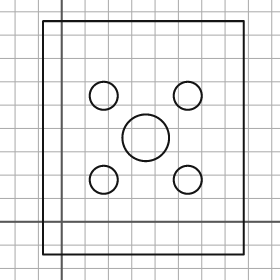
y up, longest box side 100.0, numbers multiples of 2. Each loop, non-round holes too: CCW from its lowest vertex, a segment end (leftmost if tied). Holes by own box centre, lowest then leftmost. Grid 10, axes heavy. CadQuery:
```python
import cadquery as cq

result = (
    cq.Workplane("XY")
    .moveTo(-8.0, -14.0)
    .lineTo(78.0, -14.0)
    .lineTo(78.0, 86.0)
    .lineTo(-8.0, 86.0)
    .close()
    .moveTo(18.0, 18.0)
    .circle(6.0)
    .moveTo(54.0, 18.0)
    .circle(6.0)
    .moveTo(36.0, 36.0)
    .circle(10.0)
    .moveTo(18.0, 54.0)
    .circle(6.0)
    .moveTo(54.0, 54.0)
    .circle(6.0)
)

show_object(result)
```